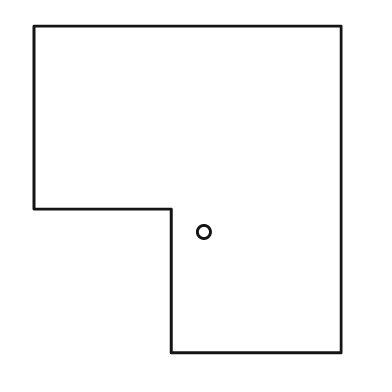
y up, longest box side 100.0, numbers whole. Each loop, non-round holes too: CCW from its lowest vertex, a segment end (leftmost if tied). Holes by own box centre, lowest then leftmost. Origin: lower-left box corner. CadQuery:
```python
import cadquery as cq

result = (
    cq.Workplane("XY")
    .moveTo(42.0, 0.0)
    .lineTo(94.0, 0.0)
    .lineTo(94.0, 100.0)
    .lineTo(0.0, 100.0)
    .lineTo(0.0, 44.0)
    .lineTo(42.0, 44.0)
    .close()
    .moveTo(52.0, 37.0)
    .circle(2.0)
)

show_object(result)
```